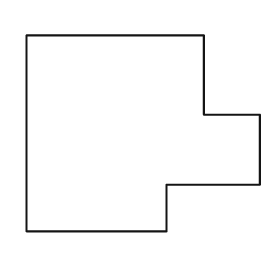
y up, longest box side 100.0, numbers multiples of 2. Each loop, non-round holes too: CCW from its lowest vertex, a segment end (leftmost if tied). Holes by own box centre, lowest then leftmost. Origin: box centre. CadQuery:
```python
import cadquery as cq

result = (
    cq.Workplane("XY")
    .moveTo(-50.0, -42.0)
    .lineTo(10.0, -42.0)
    .lineTo(10.0, -22.0)
    .lineTo(50.0, -22.0)
    .lineTo(50.0, 8.0)
    .lineTo(26.0, 8.0)
    .lineTo(26.0, 42.0)
    .lineTo(-50.0, 42.0)
    .close()
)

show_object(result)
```